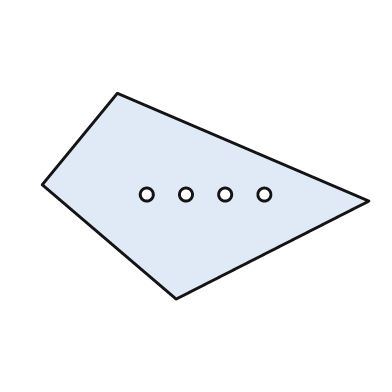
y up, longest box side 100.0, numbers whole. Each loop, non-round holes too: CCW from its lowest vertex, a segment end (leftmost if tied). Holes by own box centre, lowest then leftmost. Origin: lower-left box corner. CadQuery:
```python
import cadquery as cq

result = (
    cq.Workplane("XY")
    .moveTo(41.0, 0.0)
    .lineTo(100.0, 30.0)
    .lineTo(23.0, 63.0)
    .lineTo(0.0, 35.0)
    .close()
    .moveTo(32.0, 32.0)
    .circle(2.0)
    .moveTo(44.0, 32.0)
    .circle(2.0)
    .moveTo(56.0, 32.0)
    .circle(2.0)
    .moveTo(68.0, 32.0)
    .circle(2.0)
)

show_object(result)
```